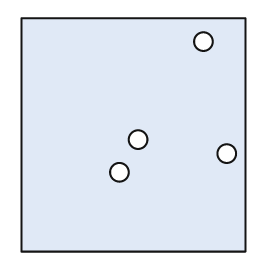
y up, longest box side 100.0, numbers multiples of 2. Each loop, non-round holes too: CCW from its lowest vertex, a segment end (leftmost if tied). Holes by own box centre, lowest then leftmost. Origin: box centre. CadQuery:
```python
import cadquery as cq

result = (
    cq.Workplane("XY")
    .moveTo(-48.0, -50.0)
    .lineTo(48.0, -50.0)
    .lineTo(48.0, 50.0)
    .lineTo(-48.0, 50.0)
    .close()
    .moveTo(-6.0, -16.0)
    .circle(4.0)
    .moveTo(40.0, -8.0)
    .circle(4.0)
    .moveTo(2.0, -2.0)
    .circle(4.0)
    .moveTo(30.0, 40.0)
    .circle(4.0)
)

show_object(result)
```